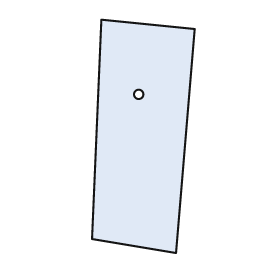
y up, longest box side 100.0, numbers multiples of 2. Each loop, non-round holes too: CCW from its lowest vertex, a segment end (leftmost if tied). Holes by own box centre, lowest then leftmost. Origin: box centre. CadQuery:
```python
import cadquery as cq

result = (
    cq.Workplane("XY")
    .moveTo(14.0, -50.0)
    .lineTo(22.0, 46.0)
    .lineTo(-18.0, 50.0)
    .lineTo(-22.0, -44.0)
    .close()
    .moveTo(-2.0, 18.0)
    .circle(2.0)
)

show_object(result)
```